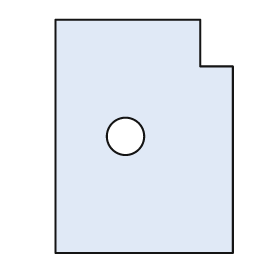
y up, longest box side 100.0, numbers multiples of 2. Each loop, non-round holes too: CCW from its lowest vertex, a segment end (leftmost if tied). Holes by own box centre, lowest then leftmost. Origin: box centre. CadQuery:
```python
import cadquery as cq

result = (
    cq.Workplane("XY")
    .moveTo(-38.0, -50.0)
    .lineTo(38.0, -50.0)
    .lineTo(38.0, 30.0)
    .lineTo(24.0, 30.0)
    .lineTo(24.0, 50.0)
    .lineTo(-38.0, 50.0)
    .close()
    .moveTo(-8.0, 0.0)
    .circle(8.0)
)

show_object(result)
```